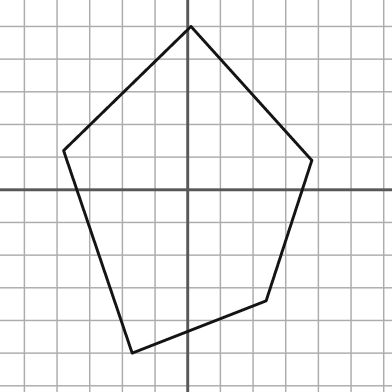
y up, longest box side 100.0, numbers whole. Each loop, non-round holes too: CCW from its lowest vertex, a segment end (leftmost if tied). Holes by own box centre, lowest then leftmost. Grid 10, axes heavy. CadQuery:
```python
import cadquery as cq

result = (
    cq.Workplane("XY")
    .moveTo(-17.0, -50.0)
    .lineTo(24.0, -34.0)
    .lineTo(38.0, 9.0)
    .lineTo(1.0, 50.0)
    .lineTo(-38.0, 12.0)
    .close()
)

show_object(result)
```